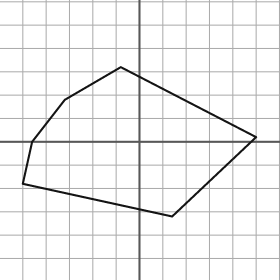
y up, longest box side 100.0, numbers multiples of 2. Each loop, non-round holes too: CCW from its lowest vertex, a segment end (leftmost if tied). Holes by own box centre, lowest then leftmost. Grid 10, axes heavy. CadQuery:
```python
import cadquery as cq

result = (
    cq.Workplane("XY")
    .moveTo(14.0, -32.0)
    .lineTo(50.0, 2.0)
    .lineTo(-8.0, 32.0)
    .lineTo(-32.0, 18.0)
    .lineTo(-46.0, 0.0)
    .lineTo(-50.0, -18.0)
    .close()
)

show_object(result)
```